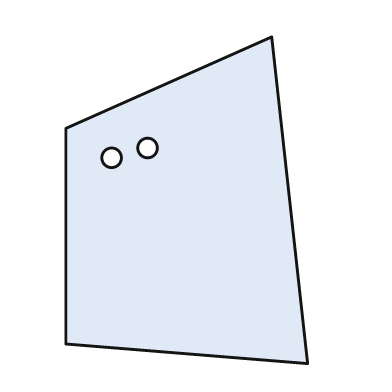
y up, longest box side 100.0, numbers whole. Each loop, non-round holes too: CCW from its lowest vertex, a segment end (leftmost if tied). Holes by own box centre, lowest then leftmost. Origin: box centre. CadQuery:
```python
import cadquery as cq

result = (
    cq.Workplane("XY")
    .moveTo(37.0, -50.0)
    .lineTo(26.0, 50.0)
    .lineTo(-37.0, 22.0)
    .lineTo(-37.0, -44.0)
    .close()
    .moveTo(-23.0, 13.0)
    .circle(3.0)
    .moveTo(-12.0, 16.0)
    .circle(3.0)
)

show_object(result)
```